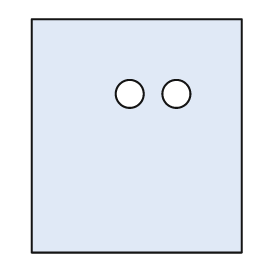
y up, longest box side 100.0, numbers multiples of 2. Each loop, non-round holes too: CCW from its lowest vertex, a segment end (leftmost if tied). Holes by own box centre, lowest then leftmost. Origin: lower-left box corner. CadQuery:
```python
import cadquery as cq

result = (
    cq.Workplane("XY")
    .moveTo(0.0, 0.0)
    .lineTo(90.0, 0.0)
    .lineTo(90.0, 100.0)
    .lineTo(0.0, 100.0)
    .close()
    .moveTo(42.0, 68.0)
    .circle(6.0)
    .moveTo(62.0, 68.0)
    .circle(6.0)
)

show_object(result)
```